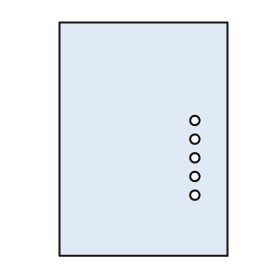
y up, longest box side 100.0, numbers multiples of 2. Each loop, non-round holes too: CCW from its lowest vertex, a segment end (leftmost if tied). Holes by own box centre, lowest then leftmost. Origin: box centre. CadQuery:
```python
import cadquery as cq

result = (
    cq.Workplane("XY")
    .moveTo(-36.0, -50.0)
    .lineTo(36.0, -50.0)
    .lineTo(36.0, 50.0)
    .lineTo(-36.0, 50.0)
    .close()
    .moveTo(22.0, -24.0)
    .circle(2.0)
    .moveTo(22.0, -16.0)
    .circle(2.0)
    .moveTo(22.0, -8.0)
    .circle(2.0)
    .moveTo(22.0, 0.0)
    .circle(2.0)
    .moveTo(22.0, 8.0)
    .circle(2.0)
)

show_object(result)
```